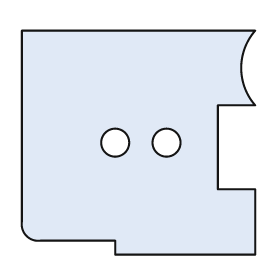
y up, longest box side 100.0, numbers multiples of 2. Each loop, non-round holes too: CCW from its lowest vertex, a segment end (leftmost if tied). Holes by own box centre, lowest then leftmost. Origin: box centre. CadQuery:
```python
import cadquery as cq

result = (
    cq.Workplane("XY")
    .moveTo(-10.0, -48.0)
    .lineTo(50.0, -48.0)
    .lineTo(50.0, -20.0)
    .lineTo(34.0, -20.0)
    .lineTo(34.0, 16.0)
    .lineTo(50.0, 16.0)
    .threePointArc((44.0, 32.0), (50.0, 48.0))
    .lineTo(-50.0, 48.0)
    .lineTo(-50.0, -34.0)
    .threePointArc((-48.0, -40.0), (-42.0, -42.0))
    .lineTo(-10.0, -42.0)
    .close()
    .moveTo(-10.0, 0.0)
    .circle(6.0)
    .moveTo(12.0, 0.0)
    .circle(6.0)
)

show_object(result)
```